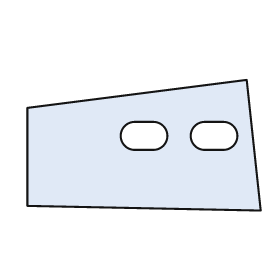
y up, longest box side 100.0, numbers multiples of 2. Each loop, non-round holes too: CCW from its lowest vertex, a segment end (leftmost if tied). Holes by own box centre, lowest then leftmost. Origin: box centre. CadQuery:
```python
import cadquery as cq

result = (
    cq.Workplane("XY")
    .moveTo(50.0, -28.0)
    .lineTo(44.0, 28.0)
    .lineTo(-50.0, 16.0)
    .lineTo(-50.0, -26.0)
    .close()
    .moveTo(-4.0, -2.0)
    .lineTo(4.0, -2.0)
    .threePointArc((10.0, 4.0), (4.0, 10.0))
    .lineTo(-4.0, 10.0)
    .threePointArc((-10.0, 4.0), (-4.0, -2.0))
    .close()
    .moveTo(26.0, -2.0)
    .lineTo(34.0, -2.0)
    .threePointArc((40.0, 4.0), (34.0, 10.0))
    .lineTo(26.0, 10.0)
    .threePointArc((20.0, 4.0), (26.0, -2.0))
    .close()
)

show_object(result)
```